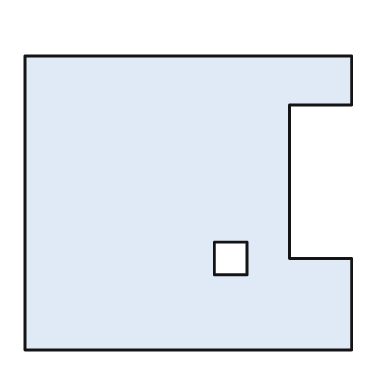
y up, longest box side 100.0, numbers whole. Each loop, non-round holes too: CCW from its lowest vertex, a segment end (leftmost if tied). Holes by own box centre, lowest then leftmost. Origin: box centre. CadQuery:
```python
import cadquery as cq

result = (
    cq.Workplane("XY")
    .moveTo(-50.0, -45.0)
    .lineTo(50.0, -45.0)
    .lineTo(50.0, -17.0)
    .lineTo(31.0, -17.0)
    .lineTo(31.0, 30.0)
    .lineTo(50.0, 30.0)
    .lineTo(50.0, 45.0)
    .lineTo(-50.0, 45.0)
    .close()
    .moveTo(8.0, -22.0)
    .lineTo(18.0, -22.0)
    .lineTo(18.0, -12.0)
    .lineTo(8.0, -12.0)
    .close()
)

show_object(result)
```